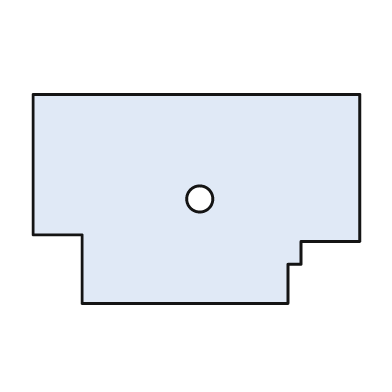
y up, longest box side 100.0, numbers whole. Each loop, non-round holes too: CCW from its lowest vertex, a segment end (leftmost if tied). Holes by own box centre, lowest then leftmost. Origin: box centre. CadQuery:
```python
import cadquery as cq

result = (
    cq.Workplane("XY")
    .moveTo(-35.0, -32.0)
    .lineTo(28.0, -32.0)
    .lineTo(28.0, -20.0)
    .lineTo(32.0, -20.0)
    .lineTo(32.0, -13.0)
    .lineTo(50.0, -13.0)
    .lineTo(50.0, 32.0)
    .lineTo(-50.0, 32.0)
    .lineTo(-50.0, -11.0)
    .lineTo(-35.0, -11.0)
    .close()
    .moveTo(1.0, 0.0)
    .circle(4.0)
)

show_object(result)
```